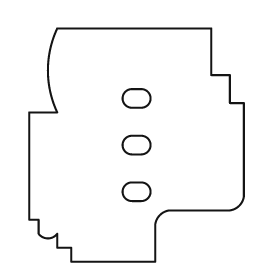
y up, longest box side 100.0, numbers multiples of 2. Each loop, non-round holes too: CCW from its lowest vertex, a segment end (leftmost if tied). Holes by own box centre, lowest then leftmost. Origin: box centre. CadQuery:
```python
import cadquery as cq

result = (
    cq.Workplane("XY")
    .moveTo(-28.0, -50.0)
    .lineTo(8.0, -50.0)
    .lineTo(8.0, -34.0)
    .threePointArc((10.0, -30.0), (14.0, -28.0))
    .lineTo(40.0, -28.0)
    .threePointArc((44.0, -26.0), (46.0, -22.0))
    .lineTo(46.0, 18.0)
    .lineTo(40.0, 18.0)
    .lineTo(40.0, 30.0)
    .lineTo(32.0, 30.0)
    .lineTo(32.0, 50.0)
    .lineTo(-34.0, 50.0)
    .threePointArc((-38.0, 32.0), (-34.0, 14.0))
    .lineTo(-46.0, 14.0)
    .lineTo(-46.0, -32.0)
    .lineTo(-42.0, -32.0)
    .lineTo(-42.0, -38.0)
    .threePointArc((-38.0, -40.0), (-34.0, -38.0))
    .lineTo(-34.0, -44.0)
    .lineTo(-28.0, -44.0)
    .close()
    .moveTo(-2.0, -24.0)
    .lineTo(2.0, -24.0)
    .threePointArc((6.0, -20.0), (2.0, -16.0))
    .lineTo(-2.0, -16.0)
    .threePointArc((-6.0, -20.0), (-2.0, -24.0))
    .close()
    .moveTo(-2.0, -4.0)
    .lineTo(2.0, -4.0)
    .threePointArc((6.0, 0.0), (2.0, 4.0))
    .lineTo(-2.0, 4.0)
    .threePointArc((-6.0, 0.0), (-2.0, -4.0))
    .close()
    .moveTo(-2.0, 16.0)
    .lineTo(2.0, 16.0)
    .threePointArc((6.0, 20.0), (2.0, 24.0))
    .lineTo(-2.0, 24.0)
    .threePointArc((-6.0, 20.0), (-2.0, 16.0))
    .close()
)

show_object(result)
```